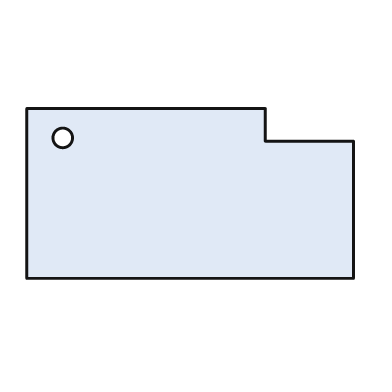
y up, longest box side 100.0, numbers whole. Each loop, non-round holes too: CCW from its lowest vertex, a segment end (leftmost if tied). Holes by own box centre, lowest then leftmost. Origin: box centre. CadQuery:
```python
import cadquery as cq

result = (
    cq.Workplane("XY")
    .moveTo(-50.0, -26.0)
    .lineTo(50.0, -26.0)
    .lineTo(50.0, 16.0)
    .lineTo(23.0, 16.0)
    .lineTo(23.0, 26.0)
    .lineTo(-50.0, 26.0)
    .close()
    .moveTo(-39.0, 17.0)
    .circle(3.0)
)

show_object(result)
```